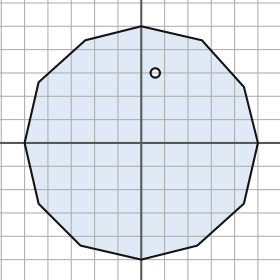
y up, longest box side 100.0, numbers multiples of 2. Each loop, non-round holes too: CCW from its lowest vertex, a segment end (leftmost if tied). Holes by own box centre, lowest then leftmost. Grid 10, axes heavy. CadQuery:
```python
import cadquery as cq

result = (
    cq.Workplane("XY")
    .moveTo(0.0, -50.0)
    .lineTo(24.0, -44.0)
    .lineTo(44.0, -26.0)
    .lineTo(50.0, 0.0)
    .lineTo(44.0, 24.0)
    .lineTo(26.0, 44.0)
    .lineTo(0.0, 50.0)
    .lineTo(-24.0, 44.0)
    .lineTo(-44.0, 26.0)
    .lineTo(-50.0, 0.0)
    .lineTo(-44.0, -26.0)
    .lineTo(-26.0, -44.0)
    .close()
    .moveTo(6.0, 30.0)
    .circle(2.0)
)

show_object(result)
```